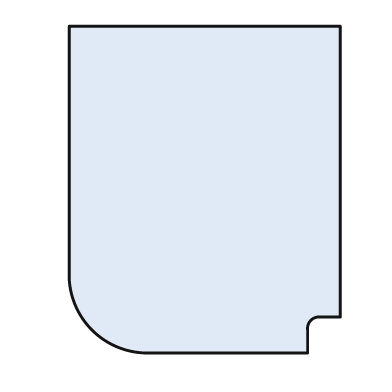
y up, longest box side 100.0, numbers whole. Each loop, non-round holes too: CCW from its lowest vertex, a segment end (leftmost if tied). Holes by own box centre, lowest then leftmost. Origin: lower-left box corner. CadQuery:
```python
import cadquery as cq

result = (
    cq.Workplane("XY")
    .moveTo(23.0, 0.0)
    .lineTo(73.0, 0.0)
    .lineTo(73.0, 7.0)
    .threePointArc((74.0, 10.0), (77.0, 11.0))
    .lineTo(83.0, 11.0)
    .lineTo(83.0, 100.0)
    .lineTo(0.0, 100.0)
    .lineTo(0.0, 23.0)
    .threePointArc((7.0, 7.0), (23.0, 0.0))
    .close()
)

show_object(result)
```